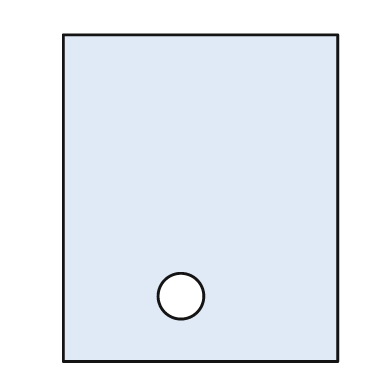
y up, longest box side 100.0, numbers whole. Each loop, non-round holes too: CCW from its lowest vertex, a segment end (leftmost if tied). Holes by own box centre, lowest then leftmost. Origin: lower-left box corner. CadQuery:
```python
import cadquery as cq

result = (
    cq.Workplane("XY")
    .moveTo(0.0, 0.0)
    .lineTo(84.0, 0.0)
    .lineTo(84.0, 100.0)
    .lineTo(0.0, 100.0)
    .close()
    .moveTo(36.0, 20.0)
    .circle(7.0)
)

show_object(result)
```